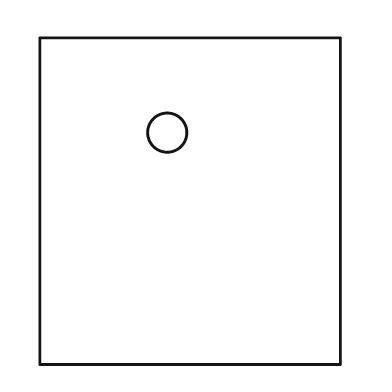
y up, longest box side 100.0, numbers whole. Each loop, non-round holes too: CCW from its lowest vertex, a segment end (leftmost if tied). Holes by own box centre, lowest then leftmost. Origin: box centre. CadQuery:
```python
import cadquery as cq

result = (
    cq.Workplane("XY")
    .moveTo(-46.0, -50.0)
    .lineTo(46.0, -50.0)
    .lineTo(46.0, 50.0)
    .lineTo(-46.0, 50.0)
    .close()
    .moveTo(-7.0, 21.0)
    .circle(6.0)
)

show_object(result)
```